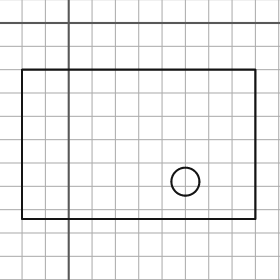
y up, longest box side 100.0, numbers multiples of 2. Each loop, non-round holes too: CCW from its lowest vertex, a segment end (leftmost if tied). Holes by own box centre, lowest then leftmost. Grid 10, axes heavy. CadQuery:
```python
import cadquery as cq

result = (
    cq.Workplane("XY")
    .moveTo(-20.0, -84.0)
    .lineTo(80.0, -84.0)
    .lineTo(80.0, -20.0)
    .lineTo(-20.0, -20.0)
    .close()
    .moveTo(50.0, -68.0)
    .circle(6.0)
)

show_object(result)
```